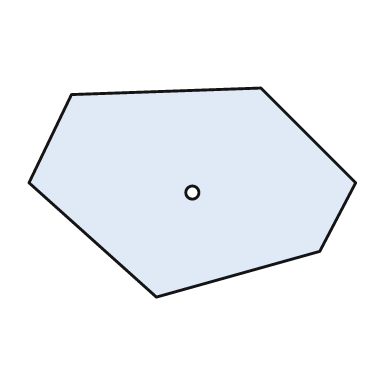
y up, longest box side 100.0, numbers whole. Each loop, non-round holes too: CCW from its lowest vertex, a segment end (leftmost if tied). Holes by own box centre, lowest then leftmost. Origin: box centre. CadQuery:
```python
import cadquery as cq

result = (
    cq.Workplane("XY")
    .moveTo(-11.0, -32.0)
    .lineTo(39.0, -18.0)
    .lineTo(50.0, 3.0)
    .lineTo(21.0, 32.0)
    .lineTo(-37.0, 30.0)
    .lineTo(-50.0, 3.0)
    .close()
    .moveTo(0.0, 0.0)
    .circle(2.0)
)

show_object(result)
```